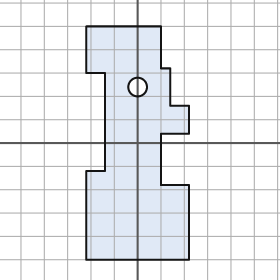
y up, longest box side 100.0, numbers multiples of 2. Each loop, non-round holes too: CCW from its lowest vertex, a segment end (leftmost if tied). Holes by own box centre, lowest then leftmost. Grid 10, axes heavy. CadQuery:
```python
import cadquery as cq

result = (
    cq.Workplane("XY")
    .moveTo(-22.0, -50.0)
    .lineTo(22.0, -50.0)
    .lineTo(22.0, -18.0)
    .lineTo(10.0, -18.0)
    .lineTo(10.0, 4.0)
    .lineTo(22.0, 4.0)
    .lineTo(22.0, 16.0)
    .lineTo(14.0, 16.0)
    .lineTo(14.0, 32.0)
    .lineTo(10.0, 32.0)
    .lineTo(10.0, 50.0)
    .lineTo(-22.0, 50.0)
    .lineTo(-22.0, 30.0)
    .lineTo(-14.0, 30.0)
    .lineTo(-14.0, -12.0)
    .lineTo(-22.0, -12.0)
    .close()
    .moveTo(0.0, 24.0)
    .circle(4.0)
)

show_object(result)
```